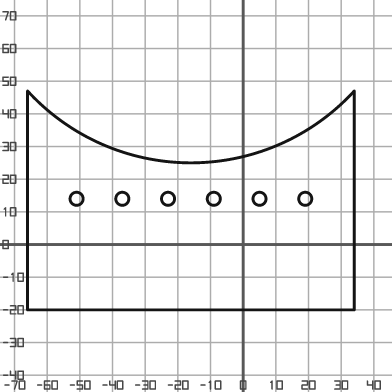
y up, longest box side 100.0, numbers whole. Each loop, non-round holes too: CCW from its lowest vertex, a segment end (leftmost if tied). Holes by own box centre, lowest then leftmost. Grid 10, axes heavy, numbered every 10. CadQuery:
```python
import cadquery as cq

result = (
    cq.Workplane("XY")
    .moveTo(-66.0, -20.0)
    .lineTo(34.0, -20.0)
    .lineTo(34.0, 47.0)
    .threePointArc((-16.0, 25.0), (-66.0, 47.0))
    .close()
    .moveTo(-51.0, 14.0)
    .circle(2.0)
    .moveTo(-37.0, 14.0)
    .circle(2.0)
    .moveTo(-23.0, 14.0)
    .circle(2.0)
    .moveTo(-9.0, 14.0)
    .circle(2.0)
    .moveTo(5.0, 14.0)
    .circle(2.0)
    .moveTo(19.0, 14.0)
    .circle(2.0)
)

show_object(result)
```